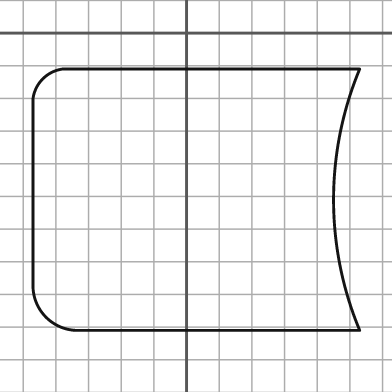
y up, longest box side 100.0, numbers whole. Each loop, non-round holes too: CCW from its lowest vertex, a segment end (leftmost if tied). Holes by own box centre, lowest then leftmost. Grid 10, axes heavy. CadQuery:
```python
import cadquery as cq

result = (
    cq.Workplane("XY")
    .moveTo(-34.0, -91.0)
    .lineTo(53.0, -91.0)
    .threePointArc((45.0, -51.0), (53.0, -11.0))
    .lineTo(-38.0, -11.0)
    .threePointArc((-44.0, -14.0), (-47.0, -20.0))
    .lineTo(-47.0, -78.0)
    .threePointArc((-43.0, -87.0), (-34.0, -91.0))
    .close()
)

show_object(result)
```